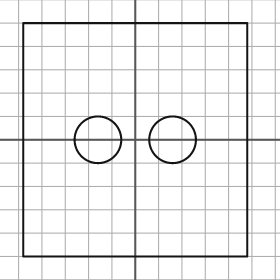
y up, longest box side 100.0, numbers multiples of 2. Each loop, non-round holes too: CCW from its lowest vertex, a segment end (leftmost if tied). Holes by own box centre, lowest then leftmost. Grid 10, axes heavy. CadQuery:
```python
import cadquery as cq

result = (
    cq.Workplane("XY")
    .moveTo(-48.0, -50.0)
    .lineTo(48.0, -50.0)
    .lineTo(48.0, 50.0)
    .lineTo(-48.0, 50.0)
    .close()
    .moveTo(-16.0, 0.0)
    .circle(10.0)
    .moveTo(16.0, 0.0)
    .circle(10.0)
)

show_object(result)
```